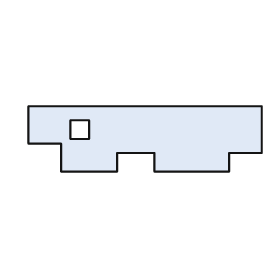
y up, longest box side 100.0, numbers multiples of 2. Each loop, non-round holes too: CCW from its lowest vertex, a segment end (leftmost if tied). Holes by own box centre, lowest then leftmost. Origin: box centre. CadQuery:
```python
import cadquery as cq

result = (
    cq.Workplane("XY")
    .moveTo(-36.0, -14.0)
    .lineTo(-12.0, -14.0)
    .lineTo(-12.0, -6.0)
    .lineTo(4.0, -6.0)
    .lineTo(4.0, -14.0)
    .lineTo(36.0, -14.0)
    .lineTo(36.0, -6.0)
    .lineTo(50.0, -6.0)
    .lineTo(50.0, 14.0)
    .lineTo(-50.0, 14.0)
    .lineTo(-50.0, -2.0)
    .lineTo(-36.0, -2.0)
    .close()
    .moveTo(-32.0, 0.0)
    .lineTo(-24.0, 0.0)
    .lineTo(-24.0, 8.0)
    .lineTo(-32.0, 8.0)
    .close()
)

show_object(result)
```